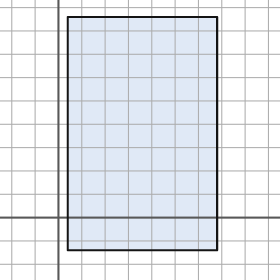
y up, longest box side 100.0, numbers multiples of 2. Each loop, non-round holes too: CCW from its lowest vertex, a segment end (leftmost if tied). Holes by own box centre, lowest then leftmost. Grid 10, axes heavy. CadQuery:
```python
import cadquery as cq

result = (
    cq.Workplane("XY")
    .moveTo(4.0, -14.0)
    .lineTo(68.0, -14.0)
    .lineTo(68.0, 86.0)
    .lineTo(4.0, 86.0)
    .close()
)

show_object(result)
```